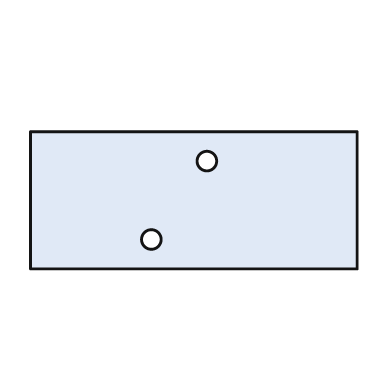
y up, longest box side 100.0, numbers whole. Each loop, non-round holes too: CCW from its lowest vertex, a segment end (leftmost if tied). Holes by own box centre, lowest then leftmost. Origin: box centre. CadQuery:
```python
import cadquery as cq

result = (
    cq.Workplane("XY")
    .moveTo(-50.0, -21.0)
    .lineTo(50.0, -21.0)
    .lineTo(50.0, 21.0)
    .lineTo(-50.0, 21.0)
    .close()
    .moveTo(-13.0, -12.0)
    .circle(3.0)
    .moveTo(4.0, 12.0)
    .circle(3.0)
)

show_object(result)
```